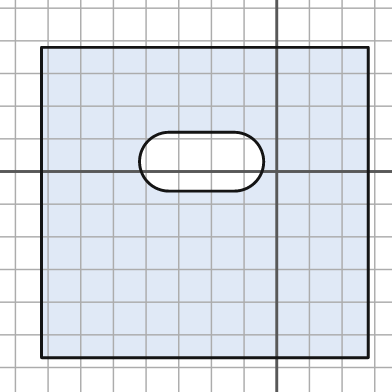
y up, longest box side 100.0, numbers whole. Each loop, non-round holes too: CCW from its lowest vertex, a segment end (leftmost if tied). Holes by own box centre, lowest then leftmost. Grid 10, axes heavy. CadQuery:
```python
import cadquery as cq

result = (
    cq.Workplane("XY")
    .moveTo(-72.0, -57.0)
    .lineTo(28.0, -57.0)
    .lineTo(28.0, 38.0)
    .lineTo(-72.0, 38.0)
    .close()
    .moveTo(-33.0, -6.0)
    .lineTo(-13.0, -6.0)
    .threePointArc((-4.0, 3.0), (-13.0, 12.0))
    .lineTo(-33.0, 12.0)
    .threePointArc((-42.0, 3.0), (-33.0, -6.0))
    .close()
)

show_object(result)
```